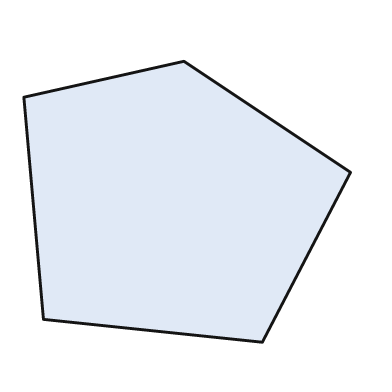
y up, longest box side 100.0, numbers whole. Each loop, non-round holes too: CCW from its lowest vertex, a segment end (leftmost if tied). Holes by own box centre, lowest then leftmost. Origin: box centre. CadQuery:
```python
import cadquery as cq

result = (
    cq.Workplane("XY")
    .moveTo(23.0, -43.0)
    .lineTo(50.0, 9.0)
    .lineTo(-1.0, 43.0)
    .lineTo(-50.0, 32.0)
    .lineTo(-44.0, -36.0)
    .close()
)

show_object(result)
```